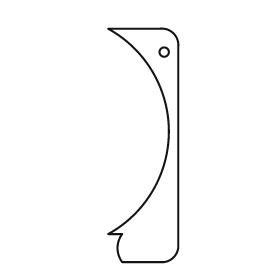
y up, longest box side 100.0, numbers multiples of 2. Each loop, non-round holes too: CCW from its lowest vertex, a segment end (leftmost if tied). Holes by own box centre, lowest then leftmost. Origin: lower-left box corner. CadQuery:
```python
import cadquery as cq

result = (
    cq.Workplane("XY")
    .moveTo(6.0, 0.0)
    .lineTo(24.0, 0.0)
    .threePointArc((28.0, 2.0), (30.0, 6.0))
    .lineTo(30.0, 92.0)
    .threePointArc((28.0, 98.0), (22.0, 100.0))
    .lineTo(0.0, 100.0)
    .threePointArc((26.0, 56.0), (0.0, 12.0))
    .lineTo(6.0, 12.0)
    .threePointArc((4.0, 6.0), (6.0, 0.0))
    .close()
    .moveTo(24.0, 90.0)
    .circle(2.0)
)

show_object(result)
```